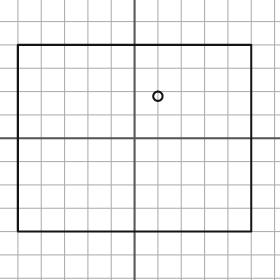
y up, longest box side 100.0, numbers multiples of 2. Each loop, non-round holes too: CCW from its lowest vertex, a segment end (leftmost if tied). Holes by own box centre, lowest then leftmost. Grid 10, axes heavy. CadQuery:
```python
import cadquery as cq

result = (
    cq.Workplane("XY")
    .moveTo(-50.0, -40.0)
    .lineTo(50.0, -40.0)
    .lineTo(50.0, 40.0)
    .lineTo(-50.0, 40.0)
    .close()
    .moveTo(10.0, 18.0)
    .circle(2.0)
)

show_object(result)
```